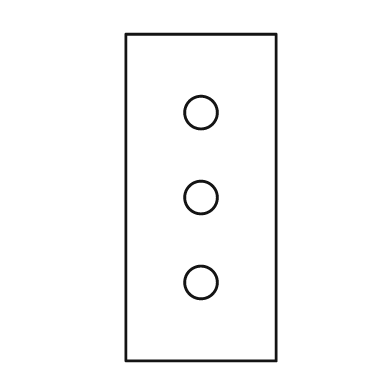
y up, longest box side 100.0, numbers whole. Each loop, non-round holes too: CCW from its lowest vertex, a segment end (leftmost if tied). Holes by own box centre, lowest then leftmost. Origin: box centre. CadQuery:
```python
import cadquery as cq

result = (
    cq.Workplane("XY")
    .moveTo(-23.0, -50.0)
    .lineTo(23.0, -50.0)
    .lineTo(23.0, 50.0)
    .lineTo(-23.0, 50.0)
    .close()
    .moveTo(0.0, -26.0)
    .circle(5.0)
    .moveTo(0.0, 0.0)
    .circle(5.0)
    .moveTo(0.0, 26.0)
    .circle(5.0)
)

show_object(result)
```